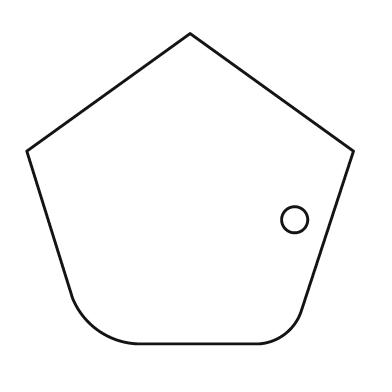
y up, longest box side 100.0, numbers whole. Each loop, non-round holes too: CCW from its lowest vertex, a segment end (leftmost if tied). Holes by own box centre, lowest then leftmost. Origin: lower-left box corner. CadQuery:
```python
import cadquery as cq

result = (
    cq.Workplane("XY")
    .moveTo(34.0, 0.0)
    .lineTo(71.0, 0.0)
    .threePointArc((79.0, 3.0), (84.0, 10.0))
    .lineTo(100.0, 59.0)
    .lineTo(50.0, 95.0)
    .lineTo(0.0, 59.0)
    .lineTo(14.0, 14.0)
    .threePointArc((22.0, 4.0), (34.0, 0.0))
    .close()
    .moveTo(82.0, 38.0)
    .circle(4.0)
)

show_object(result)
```